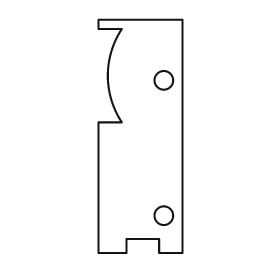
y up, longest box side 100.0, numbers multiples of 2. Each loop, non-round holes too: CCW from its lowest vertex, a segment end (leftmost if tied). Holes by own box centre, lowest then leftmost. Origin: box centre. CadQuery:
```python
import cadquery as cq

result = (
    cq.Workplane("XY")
    .moveTo(-18.0, -50.0)
    .lineTo(-6.0, -50.0)
    .lineTo(-6.0, -44.0)
    .lineTo(8.0, -44.0)
    .lineTo(8.0, -50.0)
    .lineTo(18.0, -50.0)
    .lineTo(18.0, 50.0)
    .lineTo(-18.0, 50.0)
    .lineTo(-18.0, 46.0)
    .lineTo(-8.0, 46.0)
    .threePointArc((-14.0, 26.0), (-8.0, 6.0))
    .lineTo(-18.0, 6.0)
    .close()
    .moveTo(10.0, -34.0)
    .circle(4.0)
    .moveTo(10.0, 24.0)
    .circle(4.0)
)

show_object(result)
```